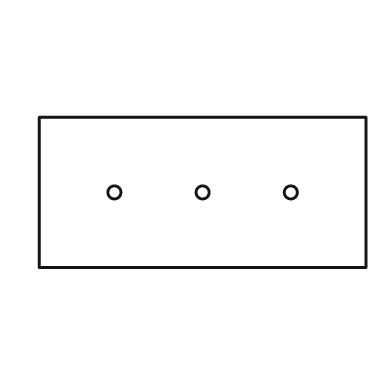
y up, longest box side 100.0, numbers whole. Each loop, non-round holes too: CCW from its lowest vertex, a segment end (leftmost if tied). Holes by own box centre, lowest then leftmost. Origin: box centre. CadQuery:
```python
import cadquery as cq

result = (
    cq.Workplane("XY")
    .moveTo(-50.0, -23.0)
    .lineTo(50.0, -23.0)
    .lineTo(50.0, 23.0)
    .lineTo(-50.0, 23.0)
    .close()
    .moveTo(-27.0, 0.0)
    .circle(2.0)
    .moveTo(0.0, 0.0)
    .circle(2.0)
    .moveTo(27.0, 0.0)
    .circle(2.0)
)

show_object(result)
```